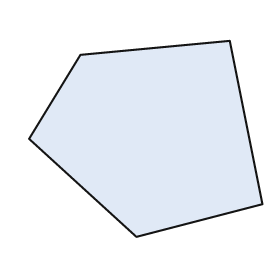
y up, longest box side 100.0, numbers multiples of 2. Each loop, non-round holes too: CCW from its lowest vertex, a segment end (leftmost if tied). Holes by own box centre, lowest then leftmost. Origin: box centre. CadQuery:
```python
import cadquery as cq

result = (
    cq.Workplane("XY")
    .moveTo(-4.0, -42.0)
    .lineTo(50.0, -28.0)
    .lineTo(36.0, 42.0)
    .lineTo(-28.0, 36.0)
    .lineTo(-50.0, 0.0)
    .close()
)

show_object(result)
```